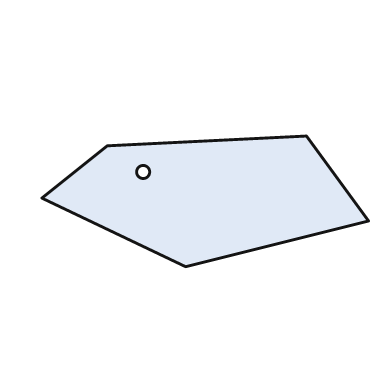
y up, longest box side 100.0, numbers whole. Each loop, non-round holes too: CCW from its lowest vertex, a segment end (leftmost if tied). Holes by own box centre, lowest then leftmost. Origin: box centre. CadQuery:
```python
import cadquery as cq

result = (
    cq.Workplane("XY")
    .moveTo(-6.0, -20.0)
    .lineTo(50.0, -6.0)
    .lineTo(31.0, 20.0)
    .lineTo(-30.0, 17.0)
    .lineTo(-50.0, 1.0)
    .close()
    .moveTo(-19.0, 9.0)
    .circle(2.0)
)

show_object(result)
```